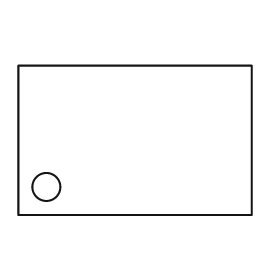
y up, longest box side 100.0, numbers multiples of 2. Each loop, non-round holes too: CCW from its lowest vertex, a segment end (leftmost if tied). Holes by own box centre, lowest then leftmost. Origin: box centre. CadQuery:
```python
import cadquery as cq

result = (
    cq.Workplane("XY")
    .moveTo(-50.0, -32.0)
    .lineTo(50.0, -32.0)
    .lineTo(50.0, 32.0)
    .lineTo(-50.0, 32.0)
    .close()
    .moveTo(-38.0, -20.0)
    .circle(6.0)
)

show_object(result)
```